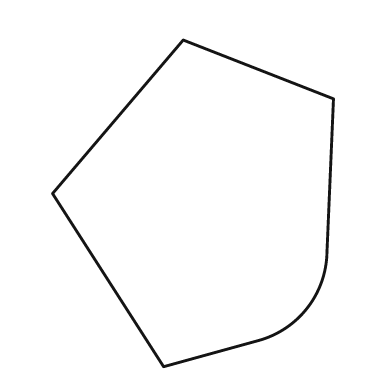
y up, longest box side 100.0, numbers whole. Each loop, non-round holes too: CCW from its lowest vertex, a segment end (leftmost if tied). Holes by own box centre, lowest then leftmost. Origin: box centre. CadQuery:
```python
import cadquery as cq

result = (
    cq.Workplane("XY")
    .moveTo(-9.0, -50.0)
    .lineTo(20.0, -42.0)
    .threePointArc((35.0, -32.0), (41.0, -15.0))
    .lineTo(43.0, 32.0)
    .lineTo(-3.0, 50.0)
    .lineTo(-43.0, 3.0)
    .close()
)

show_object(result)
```